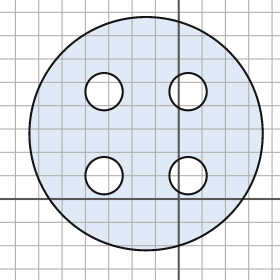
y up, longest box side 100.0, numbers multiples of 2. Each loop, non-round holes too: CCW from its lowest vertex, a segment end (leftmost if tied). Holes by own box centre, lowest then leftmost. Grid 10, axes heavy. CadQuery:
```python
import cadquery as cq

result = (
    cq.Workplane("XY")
    .moveTo(-14.0, 28.0)
    .circle(50.0)
    .moveTo(-32.0, 10.0)
    .circle(8.0)
    .moveTo(4.0, 10.0)
    .circle(8.0)
    .moveTo(-32.0, 46.0)
    .circle(8.0)
    .moveTo(4.0, 46.0)
    .circle(8.0)
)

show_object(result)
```